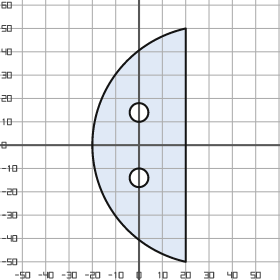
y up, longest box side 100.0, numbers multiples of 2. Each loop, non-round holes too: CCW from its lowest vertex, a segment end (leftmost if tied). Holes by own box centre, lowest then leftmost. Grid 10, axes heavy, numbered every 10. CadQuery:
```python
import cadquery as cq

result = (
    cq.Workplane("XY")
    .moveTo(20.0, -50.0)
    .lineTo(20.0, 50.0)
    .threePointArc((-20.0, 0.0), (20.0, -50.0))
    .close()
    .moveTo(0.0, -14.0)
    .circle(4.0)
    .moveTo(0.0, 14.0)
    .circle(4.0)
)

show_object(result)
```